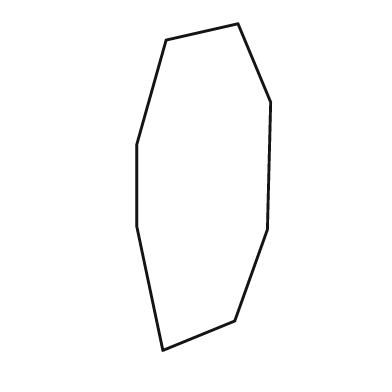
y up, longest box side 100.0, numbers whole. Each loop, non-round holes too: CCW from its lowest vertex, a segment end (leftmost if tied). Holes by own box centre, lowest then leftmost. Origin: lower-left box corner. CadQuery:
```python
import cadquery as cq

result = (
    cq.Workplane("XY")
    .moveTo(8.0, 0.0)
    .lineTo(30.0, 9.0)
    .lineTo(40.0, 37.0)
    .lineTo(41.0, 76.0)
    .lineTo(31.0, 100.0)
    .lineTo(9.0, 95.0)
    .lineTo(0.0, 63.0)
    .lineTo(0.0, 38.0)
    .close()
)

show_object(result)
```